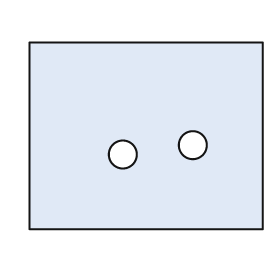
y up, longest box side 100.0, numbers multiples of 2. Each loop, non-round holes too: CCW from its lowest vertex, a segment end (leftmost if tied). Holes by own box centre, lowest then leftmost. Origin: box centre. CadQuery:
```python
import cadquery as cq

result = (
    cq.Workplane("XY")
    .moveTo(-50.0, -40.0)
    .lineTo(50.0, -40.0)
    .lineTo(50.0, 40.0)
    .lineTo(-50.0, 40.0)
    .close()
    .moveTo(-10.0, -8.0)
    .circle(6.0)
    .moveTo(20.0, -4.0)
    .circle(6.0)
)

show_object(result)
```